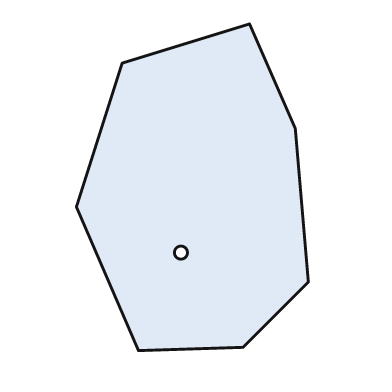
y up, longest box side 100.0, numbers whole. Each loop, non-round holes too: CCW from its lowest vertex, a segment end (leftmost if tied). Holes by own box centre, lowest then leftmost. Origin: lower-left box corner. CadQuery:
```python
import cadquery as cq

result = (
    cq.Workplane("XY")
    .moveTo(19.0, 0.0)
    .lineTo(51.0, 1.0)
    .lineTo(71.0, 21.0)
    .lineTo(67.0, 68.0)
    .lineTo(53.0, 100.0)
    .lineTo(14.0, 88.0)
    .lineTo(0.0, 44.0)
    .close()
    .moveTo(32.0, 30.0)
    .circle(2.0)
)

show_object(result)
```